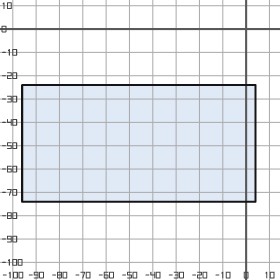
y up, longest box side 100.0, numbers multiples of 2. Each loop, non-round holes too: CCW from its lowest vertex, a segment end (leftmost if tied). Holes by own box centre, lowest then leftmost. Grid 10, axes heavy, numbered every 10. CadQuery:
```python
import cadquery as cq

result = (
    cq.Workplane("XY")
    .moveTo(-96.0, -74.0)
    .lineTo(4.0, -74.0)
    .lineTo(4.0, -24.0)
    .lineTo(-96.0, -24.0)
    .close()
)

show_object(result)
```